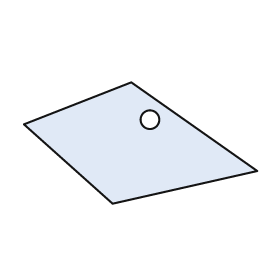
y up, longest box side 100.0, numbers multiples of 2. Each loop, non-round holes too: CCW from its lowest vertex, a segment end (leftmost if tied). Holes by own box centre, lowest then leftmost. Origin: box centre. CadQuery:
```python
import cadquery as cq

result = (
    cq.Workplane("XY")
    .moveTo(-12.0, -26.0)
    .lineTo(50.0, -12.0)
    .lineTo(-4.0, 26.0)
    .lineTo(-50.0, 8.0)
    .close()
    .moveTo(4.0, 10.0)
    .circle(4.0)
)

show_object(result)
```